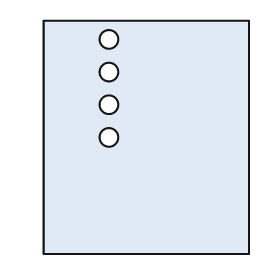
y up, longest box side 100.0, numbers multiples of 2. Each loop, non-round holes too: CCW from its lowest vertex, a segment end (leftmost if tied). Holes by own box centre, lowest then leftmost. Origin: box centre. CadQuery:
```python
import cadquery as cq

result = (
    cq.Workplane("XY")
    .moveTo(-44.0, -50.0)
    .lineTo(44.0, -50.0)
    .lineTo(44.0, 50.0)
    .lineTo(-44.0, 50.0)
    .close()
    .moveTo(-16.0, 0.0)
    .circle(4.0)
    .moveTo(-16.0, 14.0)
    .circle(4.0)
    .moveTo(-16.0, 28.0)
    .circle(4.0)
    .moveTo(-16.0, 42.0)
    .circle(4.0)
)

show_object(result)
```